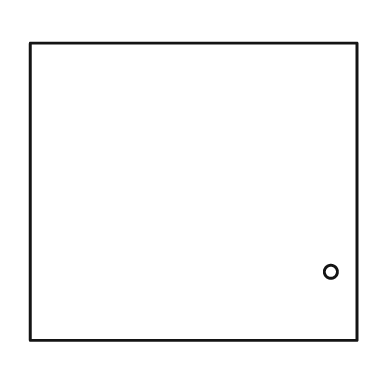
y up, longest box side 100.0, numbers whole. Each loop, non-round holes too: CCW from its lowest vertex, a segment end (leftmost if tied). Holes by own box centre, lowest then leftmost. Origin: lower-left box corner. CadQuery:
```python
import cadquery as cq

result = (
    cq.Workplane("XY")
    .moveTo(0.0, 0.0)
    .lineTo(100.0, 0.0)
    .lineTo(100.0, 91.0)
    .lineTo(0.0, 91.0)
    .close()
    .moveTo(92.0, 21.0)
    .circle(2.0)
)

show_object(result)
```